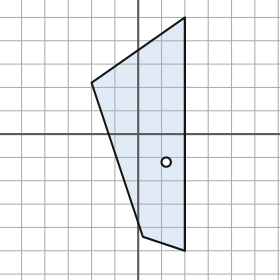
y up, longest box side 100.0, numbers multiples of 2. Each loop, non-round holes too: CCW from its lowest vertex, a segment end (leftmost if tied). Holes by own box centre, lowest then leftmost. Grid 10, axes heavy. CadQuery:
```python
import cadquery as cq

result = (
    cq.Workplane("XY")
    .moveTo(20.0, -50.0)
    .lineTo(20.0, 50.0)
    .lineTo(-20.0, 22.0)
    .lineTo(2.0, -44.0)
    .close()
    .moveTo(12.0, -12.0)
    .circle(2.0)
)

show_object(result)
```